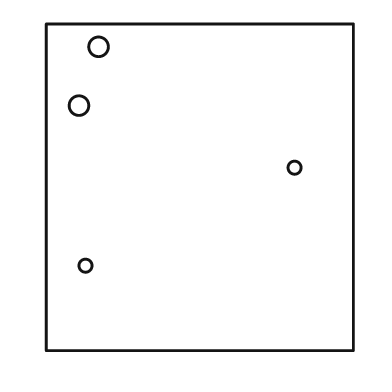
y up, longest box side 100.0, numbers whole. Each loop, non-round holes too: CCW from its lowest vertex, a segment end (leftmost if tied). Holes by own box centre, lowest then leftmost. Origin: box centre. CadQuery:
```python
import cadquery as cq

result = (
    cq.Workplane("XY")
    .moveTo(-47.0, -50.0)
    .lineTo(47.0, -50.0)
    .lineTo(47.0, 50.0)
    .lineTo(-47.0, 50.0)
    .close()
    .moveTo(-35.0, -24.0)
    .circle(2.0)
    .moveTo(29.0, 6.0)
    .circle(2.0)
    .moveTo(-37.0, 25.0)
    .circle(3.0)
    .moveTo(-31.0, 43.0)
    .circle(3.0)
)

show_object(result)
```